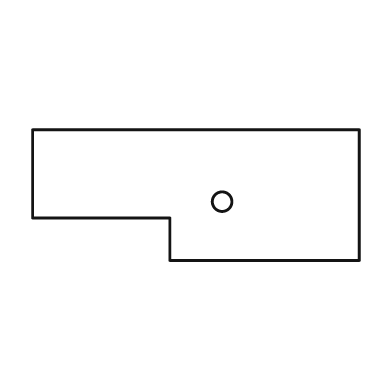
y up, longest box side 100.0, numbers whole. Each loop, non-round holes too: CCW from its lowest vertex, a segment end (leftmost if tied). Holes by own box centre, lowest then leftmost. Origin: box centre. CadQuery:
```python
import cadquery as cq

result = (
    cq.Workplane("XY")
    .moveTo(-8.0, -20.0)
    .lineTo(50.0, -20.0)
    .lineTo(50.0, 20.0)
    .lineTo(-50.0, 20.0)
    .lineTo(-50.0, -7.0)
    .lineTo(-8.0, -7.0)
    .close()
    .moveTo(8.0, -2.0)
    .circle(3.0)
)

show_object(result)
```